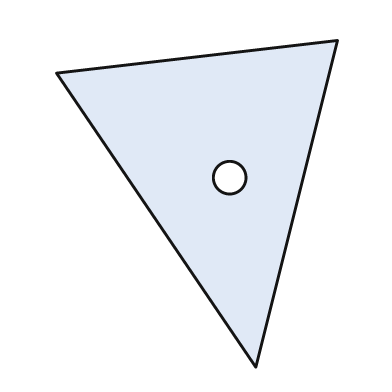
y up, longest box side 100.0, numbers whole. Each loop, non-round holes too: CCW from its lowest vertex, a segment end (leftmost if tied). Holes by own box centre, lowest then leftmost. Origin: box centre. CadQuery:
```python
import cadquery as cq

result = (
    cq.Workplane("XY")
    .moveTo(18.0, -50.0)
    .lineTo(43.0, 50.0)
    .lineTo(-43.0, 40.0)
    .close()
    .moveTo(10.0, 8.0)
    .circle(5.0)
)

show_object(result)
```